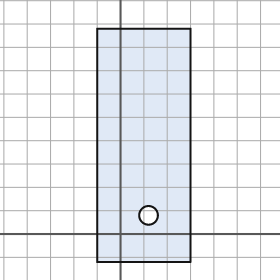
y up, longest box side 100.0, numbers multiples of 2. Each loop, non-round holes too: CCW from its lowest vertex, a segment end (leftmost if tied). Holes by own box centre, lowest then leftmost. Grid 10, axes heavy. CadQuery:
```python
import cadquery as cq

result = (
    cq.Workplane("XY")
    .moveTo(-10.0, -12.0)
    .lineTo(30.0, -12.0)
    .lineTo(30.0, 88.0)
    .lineTo(-10.0, 88.0)
    .close()
    .moveTo(12.0, 8.0)
    .circle(4.0)
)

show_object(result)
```